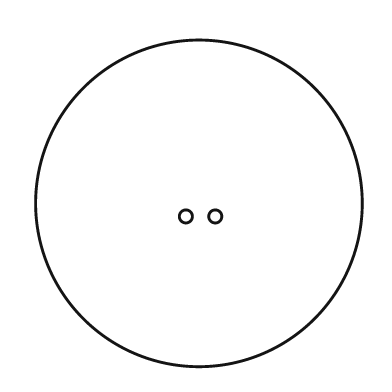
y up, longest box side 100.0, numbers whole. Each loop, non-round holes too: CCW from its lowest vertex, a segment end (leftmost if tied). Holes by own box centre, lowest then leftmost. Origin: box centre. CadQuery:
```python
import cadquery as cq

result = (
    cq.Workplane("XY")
    .moveTo(0.0, 0.0)
    .circle(50.0)
    .moveTo(-4.0, -4.0)
    .circle(2.0)
    .moveTo(5.0, -4.0)
    .circle(2.0)
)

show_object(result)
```